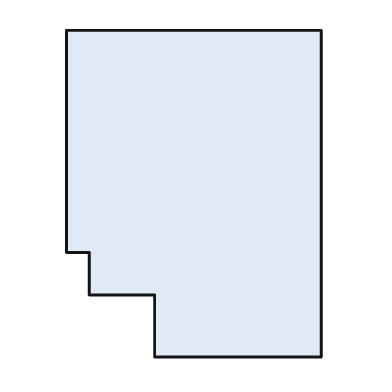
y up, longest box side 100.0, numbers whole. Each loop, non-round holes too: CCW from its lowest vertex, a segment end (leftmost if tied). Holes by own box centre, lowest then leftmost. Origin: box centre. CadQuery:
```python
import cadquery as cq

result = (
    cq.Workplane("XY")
    .moveTo(-12.0, -50.0)
    .lineTo(39.0, -50.0)
    .lineTo(39.0, 50.0)
    .lineTo(-39.0, 50.0)
    .lineTo(-39.0, -18.0)
    .lineTo(-32.0, -18.0)
    .lineTo(-32.0, -31.0)
    .lineTo(-12.0, -31.0)
    .close()
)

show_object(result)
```